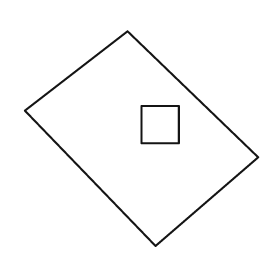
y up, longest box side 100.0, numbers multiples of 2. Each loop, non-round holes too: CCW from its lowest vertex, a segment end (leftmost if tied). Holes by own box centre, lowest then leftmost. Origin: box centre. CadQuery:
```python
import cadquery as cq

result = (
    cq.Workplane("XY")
    .moveTo(6.0, -46.0)
    .lineTo(50.0, -8.0)
    .lineTo(-6.0, 46.0)
    .lineTo(-50.0, 12.0)
    .close()
    .moveTo(0.0, -2.0)
    .lineTo(16.0, -2.0)
    .lineTo(16.0, 14.0)
    .lineTo(0.0, 14.0)
    .close()
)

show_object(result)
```